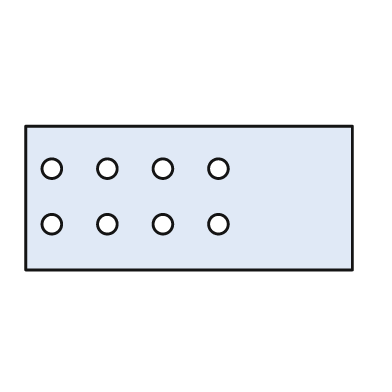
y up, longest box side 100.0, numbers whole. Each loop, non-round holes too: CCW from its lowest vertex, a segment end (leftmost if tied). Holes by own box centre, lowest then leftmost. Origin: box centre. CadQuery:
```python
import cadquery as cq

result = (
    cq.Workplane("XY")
    .moveTo(-50.0, -22.0)
    .lineTo(50.0, -22.0)
    .lineTo(50.0, 22.0)
    .lineTo(-50.0, 22.0)
    .close()
    .moveTo(-42.0, -8.0)
    .circle(3.0)
    .moveTo(-25.0, -8.0)
    .circle(3.0)
    .moveTo(-8.0, -8.0)
    .circle(3.0)
    .moveTo(9.0, -8.0)
    .circle(3.0)
    .moveTo(-42.0, 9.0)
    .circle(3.0)
    .moveTo(-25.0, 9.0)
    .circle(3.0)
    .moveTo(-8.0, 9.0)
    .circle(3.0)
    .moveTo(9.0, 9.0)
    .circle(3.0)
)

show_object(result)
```